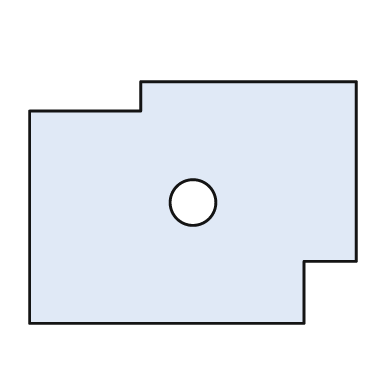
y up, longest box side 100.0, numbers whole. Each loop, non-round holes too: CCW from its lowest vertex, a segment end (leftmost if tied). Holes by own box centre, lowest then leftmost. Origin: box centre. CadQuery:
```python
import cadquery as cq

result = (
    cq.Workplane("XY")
    .moveTo(-50.0, -37.0)
    .lineTo(34.0, -37.0)
    .lineTo(34.0, -18.0)
    .lineTo(50.0, -18.0)
    .lineTo(50.0, 37.0)
    .lineTo(-16.0, 37.0)
    .lineTo(-16.0, 28.0)
    .lineTo(-50.0, 28.0)
    .close()
    .moveTo(0.0, 0.0)
    .circle(7.0)
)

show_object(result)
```